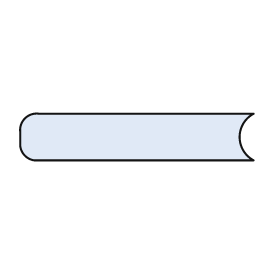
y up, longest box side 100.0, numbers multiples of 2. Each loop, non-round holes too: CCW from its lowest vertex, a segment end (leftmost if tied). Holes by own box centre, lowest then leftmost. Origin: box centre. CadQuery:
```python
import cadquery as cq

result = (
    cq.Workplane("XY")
    .moveTo(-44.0, -10.0)
    .lineTo(50.0, -10.0)
    .threePointArc((44.0, 0.0), (50.0, 10.0))
    .lineTo(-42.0, 10.0)
    .threePointArc((-48.0, 8.0), (-50.0, 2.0))
    .lineTo(-50.0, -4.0)
    .threePointArc((-48.0, -8.0), (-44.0, -10.0))
    .close()
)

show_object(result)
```